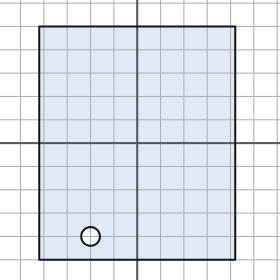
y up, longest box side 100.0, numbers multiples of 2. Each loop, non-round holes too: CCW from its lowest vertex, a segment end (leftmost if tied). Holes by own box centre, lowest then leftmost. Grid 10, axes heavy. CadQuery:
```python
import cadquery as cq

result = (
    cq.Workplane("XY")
    .moveTo(-42.0, -50.0)
    .lineTo(42.0, -50.0)
    .lineTo(42.0, 50.0)
    .lineTo(-42.0, 50.0)
    .close()
    .moveTo(-20.0, -40.0)
    .circle(4.0)
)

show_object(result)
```